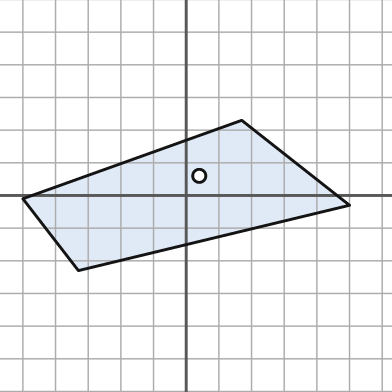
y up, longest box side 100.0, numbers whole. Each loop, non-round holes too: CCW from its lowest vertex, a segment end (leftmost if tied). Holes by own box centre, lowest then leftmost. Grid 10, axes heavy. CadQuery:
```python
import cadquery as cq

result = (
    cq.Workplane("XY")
    .moveTo(-33.0, -23.0)
    .lineTo(50.0, -3.0)
    .lineTo(17.0, 23.0)
    .lineTo(-50.0, -1.0)
    .close()
    .moveTo(4.0, 6.0)
    .circle(2.0)
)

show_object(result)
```